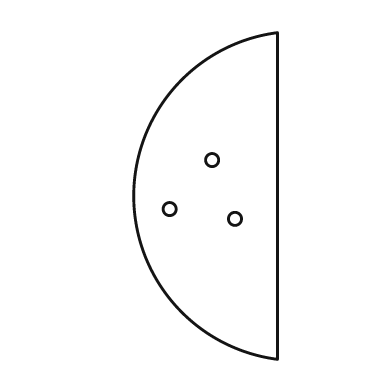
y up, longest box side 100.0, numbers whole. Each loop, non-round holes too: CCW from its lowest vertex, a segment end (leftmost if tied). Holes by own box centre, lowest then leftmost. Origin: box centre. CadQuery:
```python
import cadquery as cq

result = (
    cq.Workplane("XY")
    .moveTo(22.0, -50.0)
    .lineTo(22.0, 50.0)
    .threePointArc((-22.0, 0.0), (22.0, -50.0))
    .close()
    .moveTo(9.0, -7.0)
    .circle(2.0)
    .moveTo(-11.0, -4.0)
    .circle(2.0)
    .moveTo(2.0, 11.0)
    .circle(2.0)
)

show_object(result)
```